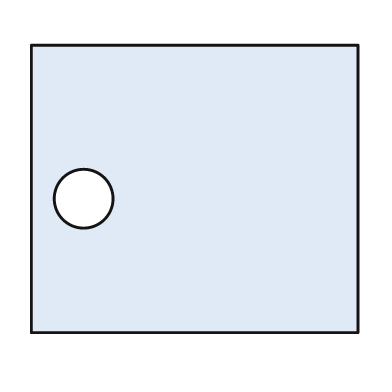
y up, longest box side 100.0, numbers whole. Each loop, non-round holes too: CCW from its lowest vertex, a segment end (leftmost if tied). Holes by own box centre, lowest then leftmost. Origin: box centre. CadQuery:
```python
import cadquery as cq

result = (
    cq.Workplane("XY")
    .moveTo(-50.0, -44.0)
    .lineTo(50.0, -44.0)
    .lineTo(50.0, 44.0)
    .lineTo(-50.0, 44.0)
    .close()
    .moveTo(-34.0, -3.0)
    .circle(9.0)
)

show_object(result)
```